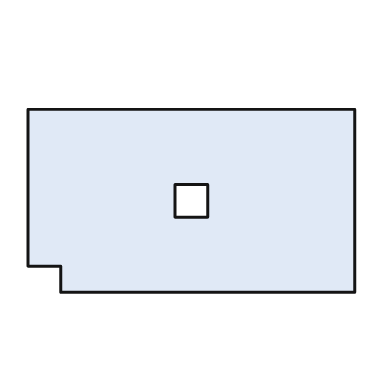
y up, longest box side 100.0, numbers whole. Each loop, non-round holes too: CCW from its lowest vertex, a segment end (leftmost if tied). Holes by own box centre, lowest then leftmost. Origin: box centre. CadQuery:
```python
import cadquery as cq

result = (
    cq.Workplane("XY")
    .moveTo(-40.0, -28.0)
    .lineTo(50.0, -28.0)
    .lineTo(50.0, 28.0)
    .lineTo(-50.0, 28.0)
    .lineTo(-50.0, -20.0)
    .lineTo(-40.0, -20.0)
    .close()
    .moveTo(-5.0, -5.0)
    .lineTo(5.0, -5.0)
    .lineTo(5.0, 5.0)
    .lineTo(-5.0, 5.0)
    .close()
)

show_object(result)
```